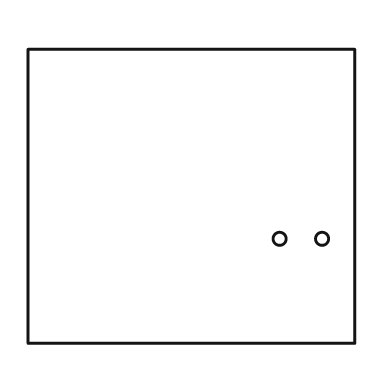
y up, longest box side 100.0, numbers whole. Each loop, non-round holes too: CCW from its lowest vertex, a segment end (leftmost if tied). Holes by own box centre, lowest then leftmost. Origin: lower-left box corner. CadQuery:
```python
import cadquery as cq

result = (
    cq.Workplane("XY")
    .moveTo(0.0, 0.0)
    .lineTo(100.0, 0.0)
    .lineTo(100.0, 90.0)
    .lineTo(0.0, 90.0)
    .close()
    .moveTo(77.0, 32.0)
    .circle(2.0)
    .moveTo(90.0, 32.0)
    .circle(2.0)
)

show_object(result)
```